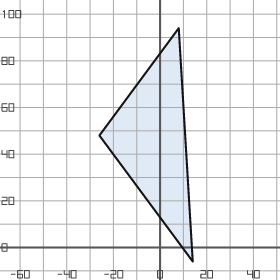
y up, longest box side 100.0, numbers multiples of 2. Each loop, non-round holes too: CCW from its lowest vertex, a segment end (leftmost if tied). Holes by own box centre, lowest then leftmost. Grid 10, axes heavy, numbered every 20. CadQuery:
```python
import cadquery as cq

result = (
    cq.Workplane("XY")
    .moveTo(14.0, -6.0)
    .lineTo(8.0, 94.0)
    .lineTo(-26.0, 48.0)
    .close()
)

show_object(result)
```